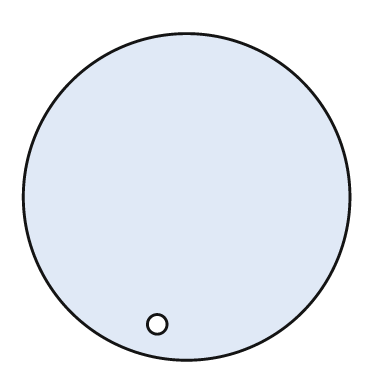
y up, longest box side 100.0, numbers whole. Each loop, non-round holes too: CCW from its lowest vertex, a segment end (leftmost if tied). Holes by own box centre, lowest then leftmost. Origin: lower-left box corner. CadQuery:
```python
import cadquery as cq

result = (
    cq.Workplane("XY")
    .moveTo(50.0, 50.0)
    .circle(50.0)
    .moveTo(41.0, 11.0)
    .circle(3.0)
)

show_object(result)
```